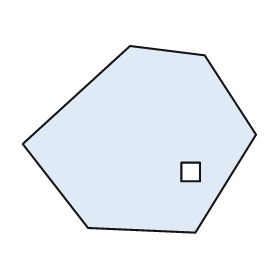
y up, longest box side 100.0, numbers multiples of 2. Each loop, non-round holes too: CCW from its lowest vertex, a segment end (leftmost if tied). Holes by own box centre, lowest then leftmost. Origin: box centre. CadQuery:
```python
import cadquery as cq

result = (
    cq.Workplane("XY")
    .moveTo(24.0, -40.0)
    .lineTo(50.0, 2.0)
    .lineTo(28.0, 36.0)
    .lineTo(-4.0, 40.0)
    .lineTo(-50.0, -2.0)
    .lineTo(-22.0, -38.0)
    .close()
    .moveTo(18.0, -18.0)
    .lineTo(26.0, -18.0)
    .lineTo(26.0, -10.0)
    .lineTo(18.0, -10.0)
    .close()
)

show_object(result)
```